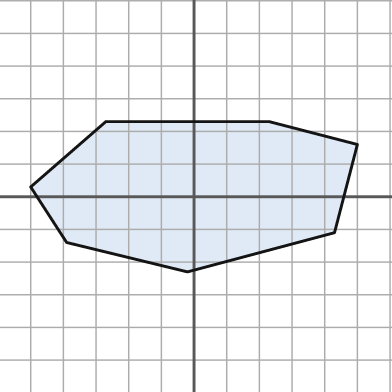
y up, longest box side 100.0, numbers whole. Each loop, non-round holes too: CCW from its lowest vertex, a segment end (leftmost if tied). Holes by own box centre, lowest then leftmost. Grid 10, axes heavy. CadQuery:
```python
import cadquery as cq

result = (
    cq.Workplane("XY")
    .moveTo(-2.0, -23.0)
    .lineTo(43.0, -11.0)
    .lineTo(50.0, 16.0)
    .lineTo(23.0, 23.0)
    .lineTo(-27.0, 23.0)
    .lineTo(-50.0, 3.0)
    .lineTo(-39.0, -14.0)
    .close()
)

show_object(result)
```